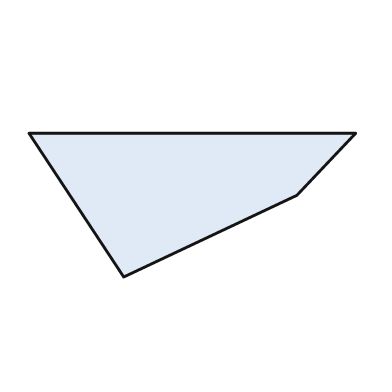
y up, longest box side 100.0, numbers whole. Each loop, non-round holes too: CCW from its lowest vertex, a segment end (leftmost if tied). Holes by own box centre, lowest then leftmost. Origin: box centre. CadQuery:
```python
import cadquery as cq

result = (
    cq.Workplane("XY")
    .moveTo(-21.0, -22.0)
    .lineTo(32.0, 3.0)
    .lineTo(50.0, 22.0)
    .lineTo(-50.0, 22.0)
    .close()
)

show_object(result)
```